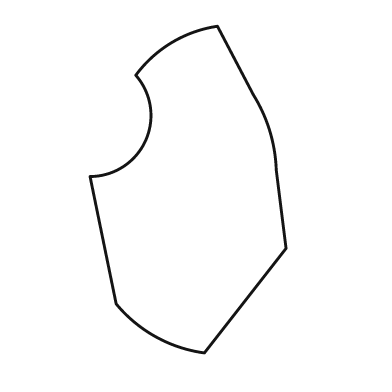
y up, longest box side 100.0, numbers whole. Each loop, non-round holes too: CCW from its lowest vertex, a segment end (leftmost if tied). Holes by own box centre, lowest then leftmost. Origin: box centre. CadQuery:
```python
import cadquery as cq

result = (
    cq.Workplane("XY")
    .moveTo(5.0, -50.0)
    .lineTo(30.0, -18.0)
    .lineTo(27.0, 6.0)
    .threePointArc((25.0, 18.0), (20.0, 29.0))
    .lineTo(9.0, 50.0)
    .threePointArc((-5.0, 45.0), (-16.0, 35.0))
    .threePointArc((-13.0, 15.0), (-30.0, 4.0))
    .lineTo(-22.0, -35.0)
    .threePointArc((-10.0, -45.0), (5.0, -50.0))
    .close()
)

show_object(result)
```